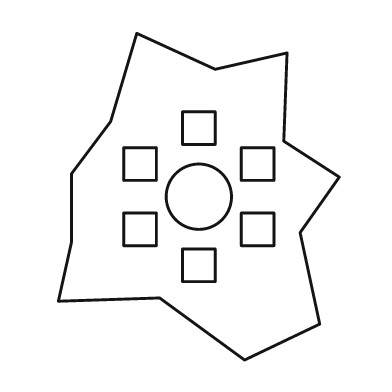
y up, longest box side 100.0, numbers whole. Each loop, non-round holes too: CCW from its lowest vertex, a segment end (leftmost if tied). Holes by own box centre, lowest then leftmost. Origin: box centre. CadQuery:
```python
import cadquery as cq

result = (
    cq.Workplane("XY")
    .moveTo(14.0, -50.0)
    .lineTo(37.0, -39.0)
    .lineTo(31.0, -11.0)
    .lineTo(43.0, 6.0)
    .lineTo(26.0, 17.0)
    .lineTo(27.0, 44.0)
    .lineTo(5.0, 39.0)
    .lineTo(-19.0, 50.0)
    .lineTo(-27.0, 23.0)
    .lineTo(-39.0, 7.0)
    .lineTo(-39.0, -14.0)
    .lineTo(-43.0, -32.0)
    .lineTo(-12.0, -31.0)
    .close()
    .moveTo(-5.0, -26.0)
    .lineTo(5.0, -26.0)
    .lineTo(5.0, -16.0)
    .lineTo(-5.0, -16.0)
    .close()
    .moveTo(-23.0, -15.0)
    .lineTo(-13.0, -15.0)
    .lineTo(-13.0, -5.0)
    .lineTo(-23.0, -5.0)
    .close()
    .moveTo(13.0, -15.0)
    .lineTo(23.0, -15.0)
    .lineTo(23.0, -5.0)
    .lineTo(13.0, -5.0)
    .close()
    .moveTo(0.0, 0.0)
    .circle(10.0)
    .moveTo(-23.0, 5.0)
    .lineTo(-13.0, 5.0)
    .lineTo(-13.0, 15.0)
    .lineTo(-23.0, 15.0)
    .close()
    .moveTo(13.0, 5.0)
    .lineTo(23.0, 5.0)
    .lineTo(23.0, 15.0)
    .lineTo(13.0, 15.0)
    .close()
    .moveTo(-5.0, 16.0)
    .lineTo(5.0, 16.0)
    .lineTo(5.0, 26.0)
    .lineTo(-5.0, 26.0)
    .close()
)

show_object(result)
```